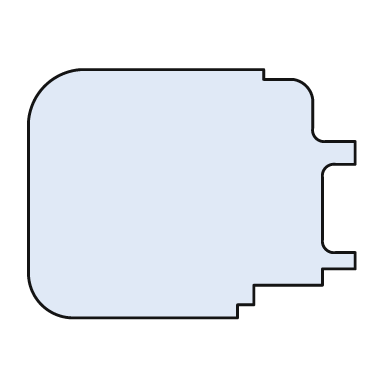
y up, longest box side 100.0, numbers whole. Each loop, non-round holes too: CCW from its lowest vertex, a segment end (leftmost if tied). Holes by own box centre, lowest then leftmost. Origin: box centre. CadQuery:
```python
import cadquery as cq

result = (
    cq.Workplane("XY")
    .moveTo(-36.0, -38.0)
    .lineTo(14.0, -38.0)
    .lineTo(14.0, -34.0)
    .lineTo(19.0, -34.0)
    .lineTo(19.0, -28.0)
    .lineTo(40.0, -28.0)
    .lineTo(40.0, -23.0)
    .lineTo(50.0, -23.0)
    .lineTo(50.0, -18.0)
    .lineTo(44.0, -18.0)
    .threePointArc((41.0, -17.0), (40.0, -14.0))
    .lineTo(40.0, 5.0)
    .threePointArc((41.0, 8.0), (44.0, 9.0))
    .lineTo(50.0, 9.0)
    .lineTo(50.0, 16.0)
    .lineTo(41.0, 16.0)
    .threePointArc((38.0, 17.0), (37.0, 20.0))
    .lineTo(37.0, 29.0)
    .threePointArc((35.0, 33.0), (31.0, 35.0))
    .lineTo(22.0, 35.0)
    .lineTo(22.0, 38.0)
    .lineTo(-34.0, 38.0)
    .threePointArc((-45.0, 33.0), (-50.0, 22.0))
    .lineTo(-50.0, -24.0)
    .threePointArc((-46.0, -34.0), (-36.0, -38.0))
    .close()
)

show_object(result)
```